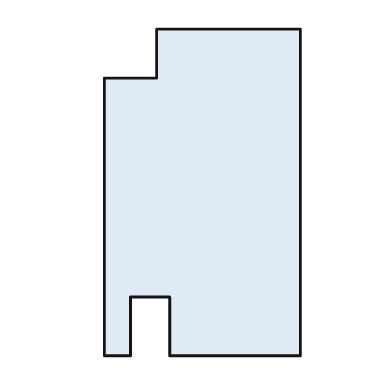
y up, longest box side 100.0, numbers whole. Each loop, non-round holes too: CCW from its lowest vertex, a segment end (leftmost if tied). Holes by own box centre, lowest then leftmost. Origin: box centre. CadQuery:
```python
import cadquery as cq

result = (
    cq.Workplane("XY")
    .moveTo(-30.0, -50.0)
    .lineTo(-22.0, -50.0)
    .lineTo(-22.0, -32.0)
    .lineTo(-10.0, -32.0)
    .lineTo(-10.0, -50.0)
    .lineTo(30.0, -50.0)
    .lineTo(30.0, 50.0)
    .lineTo(-14.0, 50.0)
    .lineTo(-14.0, 35.0)
    .lineTo(-30.0, 35.0)
    .close()
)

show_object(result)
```